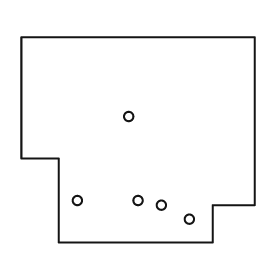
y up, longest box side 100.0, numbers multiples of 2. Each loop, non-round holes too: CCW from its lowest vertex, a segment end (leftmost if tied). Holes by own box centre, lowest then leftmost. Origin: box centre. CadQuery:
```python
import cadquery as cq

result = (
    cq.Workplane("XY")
    .moveTo(-34.0, -44.0)
    .lineTo(32.0, -44.0)
    .lineTo(32.0, -28.0)
    .lineTo(50.0, -28.0)
    .lineTo(50.0, 44.0)
    .lineTo(-50.0, 44.0)
    .lineTo(-50.0, -8.0)
    .lineTo(-34.0, -8.0)
    .close()
    .moveTo(22.0, -34.0)
    .circle(2.0)
    .moveTo(10.0, -28.0)
    .circle(2.0)
    .moveTo(-26.0, -26.0)
    .circle(2.0)
    .moveTo(0.0, -26.0)
    .circle(2.0)
    .moveTo(-4.0, 10.0)
    .circle(2.0)
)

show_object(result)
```